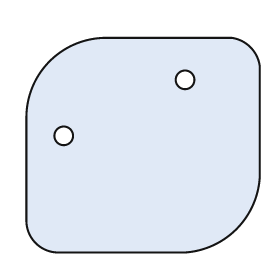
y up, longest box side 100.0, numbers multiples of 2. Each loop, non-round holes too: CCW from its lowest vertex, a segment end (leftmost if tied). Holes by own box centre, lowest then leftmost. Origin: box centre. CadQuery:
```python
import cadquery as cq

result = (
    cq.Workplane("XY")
    .moveTo(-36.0, -46.0)
    .lineTo(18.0, -46.0)
    .threePointArc((40.0, -36.0), (50.0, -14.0))
    .lineTo(50.0, 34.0)
    .threePointArc((46.0, 42.0), (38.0, 46.0))
    .lineTo(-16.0, 46.0)
    .threePointArc((-40.0, 36.0), (-50.0, 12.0))
    .lineTo(-50.0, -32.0)
    .threePointArc((-46.0, -42.0), (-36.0, -46.0))
    .close()
    .moveTo(-34.0, 4.0)
    .circle(4.0)
    .moveTo(18.0, 28.0)
    .circle(4.0)
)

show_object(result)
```